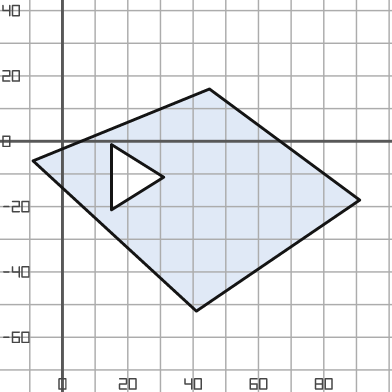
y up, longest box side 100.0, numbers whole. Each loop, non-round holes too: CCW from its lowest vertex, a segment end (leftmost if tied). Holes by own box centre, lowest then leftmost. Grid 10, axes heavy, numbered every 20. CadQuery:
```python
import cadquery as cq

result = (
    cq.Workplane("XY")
    .moveTo(41.0, -52.0)
    .lineTo(91.0, -18.0)
    .lineTo(45.0, 16.0)
    .lineTo(-9.0, -6.0)
    .close()
    .moveTo(15.0, -21.0)
    .lineTo(31.0, -11.0)
    .lineTo(15.0, -1.0)
    .close()
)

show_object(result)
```